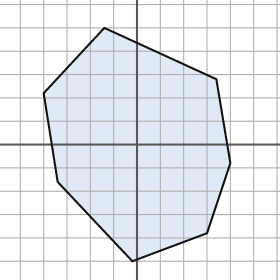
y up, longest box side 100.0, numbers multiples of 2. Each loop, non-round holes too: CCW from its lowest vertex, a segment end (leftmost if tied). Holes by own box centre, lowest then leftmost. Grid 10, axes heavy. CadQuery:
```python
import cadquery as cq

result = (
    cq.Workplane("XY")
    .moveTo(-2.0, -50.0)
    .lineTo(30.0, -38.0)
    .lineTo(40.0, -8.0)
    .lineTo(34.0, 28.0)
    .lineTo(-14.0, 50.0)
    .lineTo(-40.0, 22.0)
    .lineTo(-34.0, -16.0)
    .close()
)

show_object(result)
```